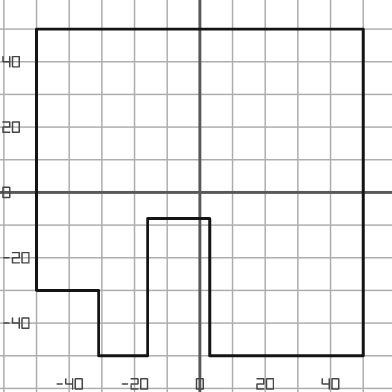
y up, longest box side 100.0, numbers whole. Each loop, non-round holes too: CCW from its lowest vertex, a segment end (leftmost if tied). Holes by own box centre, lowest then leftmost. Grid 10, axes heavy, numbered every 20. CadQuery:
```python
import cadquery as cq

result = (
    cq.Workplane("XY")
    .moveTo(-31.0, -50.0)
    .lineTo(-16.0, -50.0)
    .lineTo(-16.0, -8.0)
    .lineTo(3.0, -8.0)
    .lineTo(3.0, -50.0)
    .lineTo(50.0, -50.0)
    .lineTo(50.0, 50.0)
    .lineTo(-50.0, 50.0)
    .lineTo(-50.0, -30.0)
    .lineTo(-31.0, -30.0)
    .close()
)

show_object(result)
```